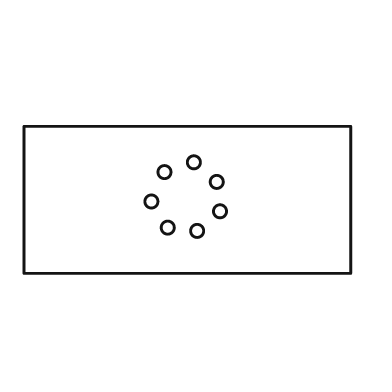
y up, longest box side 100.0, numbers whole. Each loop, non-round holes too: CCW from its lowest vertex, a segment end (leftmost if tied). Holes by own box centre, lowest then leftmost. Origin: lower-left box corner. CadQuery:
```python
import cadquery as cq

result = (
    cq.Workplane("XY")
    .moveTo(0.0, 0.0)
    .lineTo(100.0, 0.0)
    .lineTo(100.0, 45.0)
    .lineTo(0.0, 45.0)
    .close()
    .moveTo(53.0, 13.0)
    .circle(2.0)
    .moveTo(44.0, 14.0)
    .circle(2.0)
    .moveTo(60.0, 19.0)
    .circle(2.0)
    .moveTo(39.0, 22.0)
    .circle(2.0)
    .moveTo(59.0, 28.0)
    .circle(2.0)
    .moveTo(43.0, 31.0)
    .circle(2.0)
    .moveTo(52.0, 34.0)
    .circle(2.0)
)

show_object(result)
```